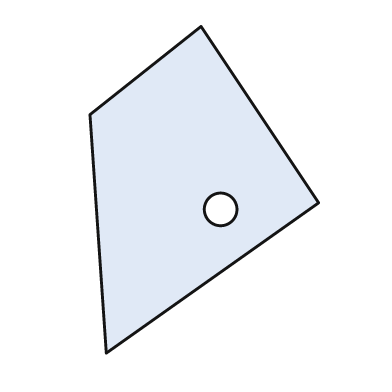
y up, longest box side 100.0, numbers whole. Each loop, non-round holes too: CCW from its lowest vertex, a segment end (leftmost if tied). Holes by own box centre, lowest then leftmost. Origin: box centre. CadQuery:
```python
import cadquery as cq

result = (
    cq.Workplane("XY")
    .moveTo(-30.0, -50.0)
    .lineTo(35.0, -4.0)
    .lineTo(-1.0, 50.0)
    .lineTo(-35.0, 23.0)
    .close()
    .moveTo(5.0, -6.0)
    .circle(5.0)
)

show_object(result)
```